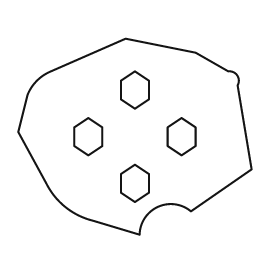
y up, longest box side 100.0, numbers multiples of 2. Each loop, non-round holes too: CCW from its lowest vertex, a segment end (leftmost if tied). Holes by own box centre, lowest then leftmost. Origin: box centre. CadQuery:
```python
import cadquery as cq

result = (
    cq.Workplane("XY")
    .moveTo(2.0, -42.0)
    .threePointArc((10.0, -30.0), (24.0, -32.0))
    .lineTo(50.0, -14.0)
    .lineTo(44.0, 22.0)
    .threePointArc((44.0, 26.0), (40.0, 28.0))
    .lineTo(26.0, 36.0)
    .lineTo(-4.0, 42.0)
    .lineTo(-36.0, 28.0)
    .threePointArc((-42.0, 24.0), (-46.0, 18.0))
    .lineTo(-50.0, 2.0)
    .lineTo(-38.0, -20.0)
    .threePointArc((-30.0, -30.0), (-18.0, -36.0))
    .close()
    .moveTo(0.0, -28.0)
    .lineTo(6.0, -24.0)
    .lineTo(6.0, -16.0)
    .lineTo(0.0, -12.0)
    .lineTo(-6.0, -16.0)
    .lineTo(-6.0, -24.0)
    .close()
    .moveTo(-20.0, -8.0)
    .lineTo(-14.0, -4.0)
    .lineTo(-14.0, 4.0)
    .lineTo(-20.0, 8.0)
    .lineTo(-26.0, 4.0)
    .lineTo(-26.0, -4.0)
    .close()
    .moveTo(20.0, -8.0)
    .lineTo(26.0, -4.0)
    .lineTo(26.0, 4.0)
    .lineTo(20.0, 8.0)
    .lineTo(14.0, 4.0)
    .lineTo(14.0, -4.0)
    .close()
    .moveTo(0.0, 12.0)
    .lineTo(6.0, 16.0)
    .lineTo(6.0, 24.0)
    .lineTo(0.0, 28.0)
    .lineTo(-6.0, 24.0)
    .lineTo(-6.0, 16.0)
    .close()
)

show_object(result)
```